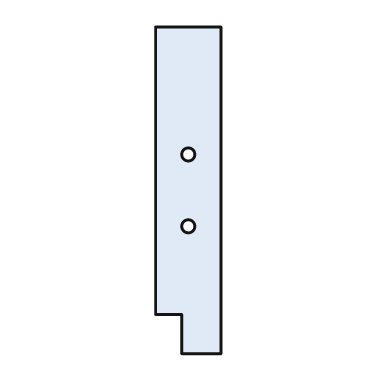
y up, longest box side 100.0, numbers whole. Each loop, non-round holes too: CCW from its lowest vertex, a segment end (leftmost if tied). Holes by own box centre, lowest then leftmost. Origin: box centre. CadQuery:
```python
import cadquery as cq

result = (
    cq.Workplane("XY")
    .moveTo(-2.0, -50.0)
    .lineTo(10.0, -50.0)
    .lineTo(10.0, 50.0)
    .lineTo(-10.0, 50.0)
    .lineTo(-10.0, -38.0)
    .lineTo(-2.0, -38.0)
    .close()
    .moveTo(0.0, -11.0)
    .circle(2.0)
    .moveTo(0.0, 11.0)
    .circle(2.0)
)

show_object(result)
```